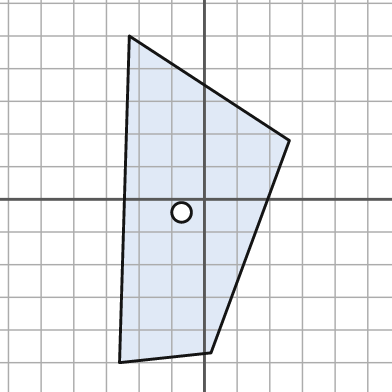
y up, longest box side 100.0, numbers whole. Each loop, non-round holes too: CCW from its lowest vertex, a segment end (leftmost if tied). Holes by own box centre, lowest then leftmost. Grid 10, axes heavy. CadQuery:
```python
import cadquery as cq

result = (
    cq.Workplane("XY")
    .moveTo(-26.0, -50.0)
    .lineTo(2.0, -47.0)
    .lineTo(26.0, 18.0)
    .lineTo(-23.0, 50.0)
    .close()
    .moveTo(-7.0, -4.0)
    .circle(3.0)
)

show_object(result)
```